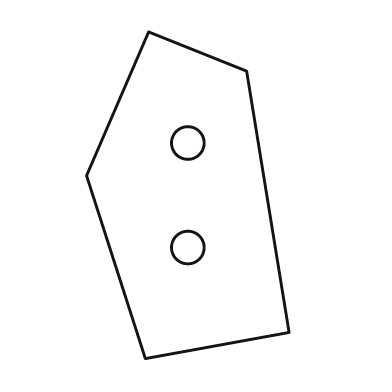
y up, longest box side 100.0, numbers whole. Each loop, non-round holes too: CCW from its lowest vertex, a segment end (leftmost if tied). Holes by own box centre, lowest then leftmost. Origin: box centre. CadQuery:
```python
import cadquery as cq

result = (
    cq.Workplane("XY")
    .moveTo(-13.0, -50.0)
    .lineTo(31.0, -42.0)
    .lineTo(18.0, 38.0)
    .lineTo(-12.0, 50.0)
    .lineTo(-31.0, 6.0)
    .close()
    .moveTo(0.0, -16.0)
    .circle(5.0)
    .moveTo(0.0, 16.0)
    .circle(5.0)
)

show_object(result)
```